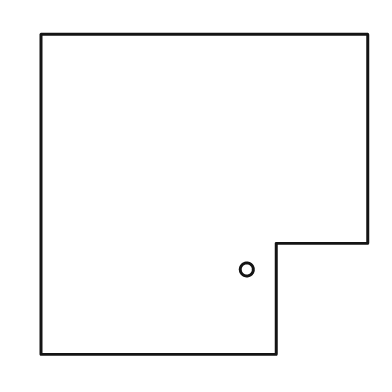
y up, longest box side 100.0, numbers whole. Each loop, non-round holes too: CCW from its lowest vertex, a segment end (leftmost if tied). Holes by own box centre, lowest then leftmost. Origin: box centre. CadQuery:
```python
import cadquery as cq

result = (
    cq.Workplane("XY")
    .moveTo(-50.0, -49.0)
    .lineTo(22.0, -49.0)
    .lineTo(22.0, -15.0)
    .lineTo(50.0, -15.0)
    .lineTo(50.0, 49.0)
    .lineTo(-50.0, 49.0)
    .close()
    .moveTo(13.0, -23.0)
    .circle(2.0)
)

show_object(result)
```